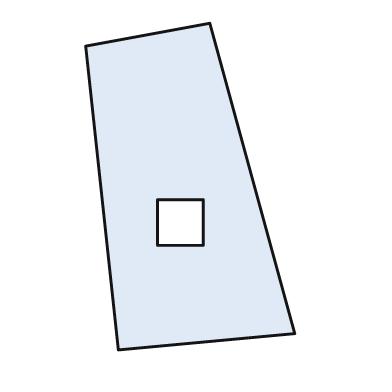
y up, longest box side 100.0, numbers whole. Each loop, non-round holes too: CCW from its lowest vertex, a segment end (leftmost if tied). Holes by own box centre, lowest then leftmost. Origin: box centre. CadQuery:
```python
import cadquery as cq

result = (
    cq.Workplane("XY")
    .moveTo(-22.0, -50.0)
    .lineTo(32.0, -45.0)
    .lineTo(6.0, 50.0)
    .lineTo(-32.0, 43.0)
    .close()
    .moveTo(-10.0, -18.0)
    .lineTo(4.0, -18.0)
    .lineTo(4.0, -4.0)
    .lineTo(-10.0, -4.0)
    .close()
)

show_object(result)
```